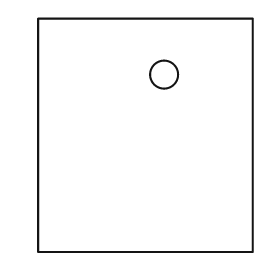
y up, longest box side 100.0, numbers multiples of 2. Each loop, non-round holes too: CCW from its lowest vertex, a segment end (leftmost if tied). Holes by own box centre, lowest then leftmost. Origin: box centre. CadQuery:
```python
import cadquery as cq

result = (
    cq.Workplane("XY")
    .moveTo(-46.0, -50.0)
    .lineTo(46.0, -50.0)
    .lineTo(46.0, 50.0)
    .lineTo(-46.0, 50.0)
    .close()
    .moveTo(8.0, 26.0)
    .circle(6.0)
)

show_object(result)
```